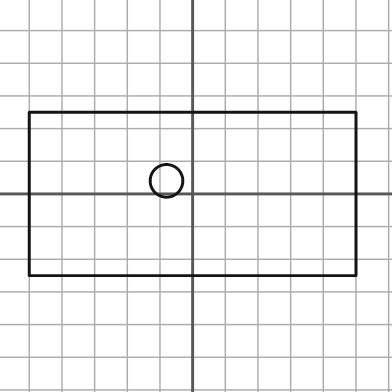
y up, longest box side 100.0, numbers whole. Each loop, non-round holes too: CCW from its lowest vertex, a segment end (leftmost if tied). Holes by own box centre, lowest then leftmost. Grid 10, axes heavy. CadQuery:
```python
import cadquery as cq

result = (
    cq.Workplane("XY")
    .moveTo(-50.0, -25.0)
    .lineTo(50.0, -25.0)
    .lineTo(50.0, 25.0)
    .lineTo(-50.0, 25.0)
    .close()
    .moveTo(-8.0, 4.0)
    .circle(5.0)
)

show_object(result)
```